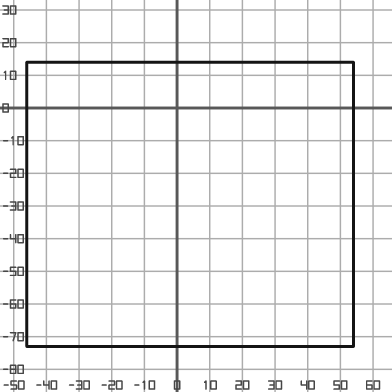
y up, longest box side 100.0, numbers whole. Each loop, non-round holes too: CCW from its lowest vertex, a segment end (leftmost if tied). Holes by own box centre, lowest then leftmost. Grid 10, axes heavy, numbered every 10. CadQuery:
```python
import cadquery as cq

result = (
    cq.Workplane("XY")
    .moveTo(-46.0, -73.0)
    .lineTo(54.0, -73.0)
    .lineTo(54.0, 14.0)
    .lineTo(-46.0, 14.0)
    .close()
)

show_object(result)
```